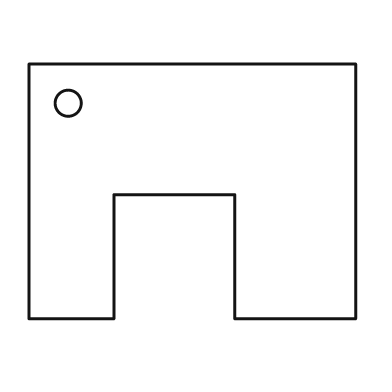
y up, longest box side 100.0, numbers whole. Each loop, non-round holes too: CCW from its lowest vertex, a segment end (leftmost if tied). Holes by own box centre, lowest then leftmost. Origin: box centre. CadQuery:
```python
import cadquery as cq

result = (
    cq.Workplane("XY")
    .moveTo(-50.0, -39.0)
    .lineTo(-24.0, -39.0)
    .lineTo(-24.0, -1.0)
    .lineTo(13.0, -1.0)
    .lineTo(13.0, -39.0)
    .lineTo(50.0, -39.0)
    .lineTo(50.0, 39.0)
    .lineTo(-50.0, 39.0)
    .close()
    .moveTo(-38.0, 27.0)
    .circle(4.0)
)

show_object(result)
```